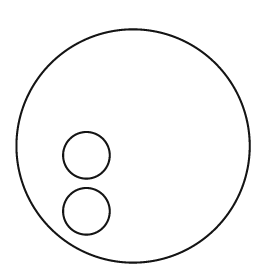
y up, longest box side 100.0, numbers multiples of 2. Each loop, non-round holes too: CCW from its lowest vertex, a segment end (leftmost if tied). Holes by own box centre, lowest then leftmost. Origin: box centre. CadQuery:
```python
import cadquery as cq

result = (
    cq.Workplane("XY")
    .moveTo(0.0, 0.0)
    .circle(50.0)
    .moveTo(-20.0, -28.0)
    .circle(10.0)
    .moveTo(-20.0, -4.0)
    .circle(10.0)
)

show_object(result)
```